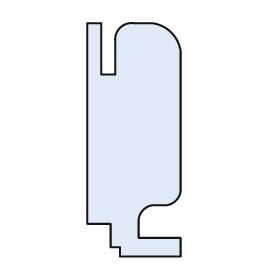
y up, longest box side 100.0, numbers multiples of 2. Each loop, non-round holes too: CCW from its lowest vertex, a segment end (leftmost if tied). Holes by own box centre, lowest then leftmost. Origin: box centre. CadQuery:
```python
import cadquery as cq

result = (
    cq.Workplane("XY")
    .moveTo(-6.0, -50.0)
    .lineTo(20.0, -50.0)
    .lineTo(20.0, -42.0)
    .lineTo(2.0, -42.0)
    .lineTo(2.0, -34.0)
    .threePointArc((4.0, -30.0), (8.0, -28.0))
    .lineTo(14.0, -28.0)
    .threePointArc((18.0, -26.0), (20.0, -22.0))
    .lineTo(20.0, 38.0)
    .threePointArc((16.0, 46.0), (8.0, 50.0))
    .lineTo(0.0, 50.0)
    .threePointArc((-6.0, 48.0), (-8.0, 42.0))
    .lineTo(-8.0, 28.0)
    .lineTo(-14.0, 28.0)
    .lineTo(-14.0, 50.0)
    .lineTo(-20.0, 50.0)
    .lineTo(-20.0, -36.0)
    .lineTo(-10.0, -36.0)
    .lineTo(-10.0, -46.0)
    .lineTo(-6.0, -46.0)
    .close()
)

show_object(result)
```